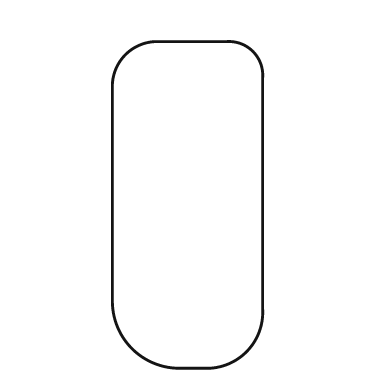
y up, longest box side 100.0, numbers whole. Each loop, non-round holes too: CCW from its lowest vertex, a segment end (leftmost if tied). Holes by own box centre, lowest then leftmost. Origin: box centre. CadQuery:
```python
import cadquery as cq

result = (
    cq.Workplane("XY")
    .moveTo(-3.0, -50.0)
    .lineTo(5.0, -50.0)
    .threePointArc((18.0, -45.0), (23.0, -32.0))
    .lineTo(23.0, 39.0)
    .threePointArc((20.0, 47.0), (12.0, 50.0))
    .lineTo(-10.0, 50.0)
    .threePointArc((-19.0, 46.0), (-23.0, 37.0))
    .lineTo(-23.0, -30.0)
    .threePointArc((-17.0, -44.0), (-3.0, -50.0))
    .close()
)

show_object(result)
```